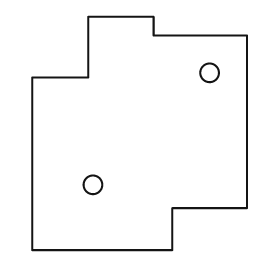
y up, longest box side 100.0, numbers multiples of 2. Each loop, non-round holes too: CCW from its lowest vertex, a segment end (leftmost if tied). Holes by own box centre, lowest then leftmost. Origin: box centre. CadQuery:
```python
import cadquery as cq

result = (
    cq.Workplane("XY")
    .moveTo(-46.0, -50.0)
    .lineTo(14.0, -50.0)
    .lineTo(14.0, -32.0)
    .lineTo(46.0, -32.0)
    .lineTo(46.0, 42.0)
    .lineTo(6.0, 42.0)
    .lineTo(6.0, 50.0)
    .lineTo(-22.0, 50.0)
    .lineTo(-22.0, 24.0)
    .lineTo(-46.0, 24.0)
    .close()
    .moveTo(-20.0, -22.0)
    .circle(4.0)
    .moveTo(30.0, 26.0)
    .circle(4.0)
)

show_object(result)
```